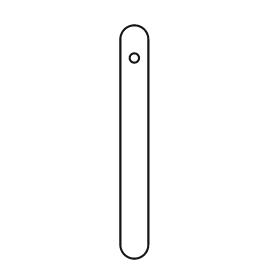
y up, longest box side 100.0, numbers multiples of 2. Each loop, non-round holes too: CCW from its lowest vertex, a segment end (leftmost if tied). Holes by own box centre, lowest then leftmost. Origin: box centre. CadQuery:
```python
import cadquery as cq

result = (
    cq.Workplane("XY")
    .moveTo(-6.0, -44.0)
    .threePointArc((0.0, -50.0), (6.0, -44.0))
    .lineTo(6.0, 44.0)
    .threePointArc((0.0, 50.0), (-6.0, 44.0))
    .close()
    .moveTo(0.0, 36.0)
    .circle(2.0)
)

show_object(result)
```